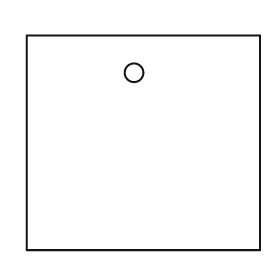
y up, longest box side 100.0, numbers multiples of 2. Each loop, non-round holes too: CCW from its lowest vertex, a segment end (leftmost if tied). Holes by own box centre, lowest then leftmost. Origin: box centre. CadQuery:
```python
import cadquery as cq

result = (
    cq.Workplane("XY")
    .moveTo(-50.0, -46.0)
    .lineTo(50.0, -46.0)
    .lineTo(50.0, 46.0)
    .lineTo(-50.0, 46.0)
    .close()
    .moveTo(-4.0, 30.0)
    .circle(4.0)
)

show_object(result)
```